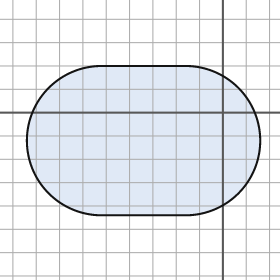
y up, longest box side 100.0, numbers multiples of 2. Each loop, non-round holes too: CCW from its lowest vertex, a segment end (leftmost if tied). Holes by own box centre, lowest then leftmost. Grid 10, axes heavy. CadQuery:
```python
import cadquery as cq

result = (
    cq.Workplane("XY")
    .moveTo(-52.0, -44.0)
    .lineTo(-16.0, -44.0)
    .threePointArc((16.0, -12.0), (-16.0, 20.0))
    .lineTo(-52.0, 20.0)
    .threePointArc((-84.0, -12.0), (-52.0, -44.0))
    .close()
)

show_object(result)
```